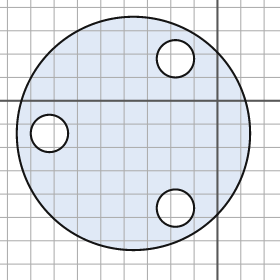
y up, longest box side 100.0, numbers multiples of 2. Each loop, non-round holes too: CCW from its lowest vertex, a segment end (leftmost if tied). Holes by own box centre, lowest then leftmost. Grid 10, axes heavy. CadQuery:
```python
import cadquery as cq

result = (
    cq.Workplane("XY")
    .moveTo(-36.0, -14.0)
    .circle(50.0)
    .moveTo(-18.0, -46.0)
    .circle(8.0)
    .moveTo(-72.0, -14.0)
    .circle(8.0)
    .moveTo(-18.0, 18.0)
    .circle(8.0)
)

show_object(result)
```